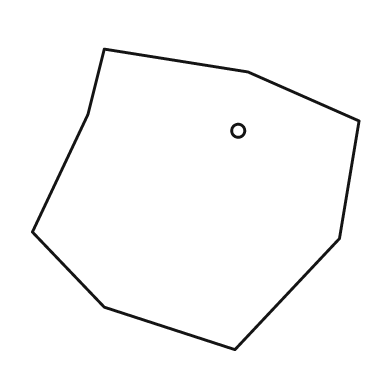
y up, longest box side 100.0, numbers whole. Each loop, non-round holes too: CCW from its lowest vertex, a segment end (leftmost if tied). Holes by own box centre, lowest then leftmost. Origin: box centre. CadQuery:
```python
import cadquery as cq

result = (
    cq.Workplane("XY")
    .moveTo(12.0, -46.0)
    .lineTo(44.0, -12.0)
    .lineTo(50.0, 24.0)
    .lineTo(16.0, 39.0)
    .lineTo(-28.0, 46.0)
    .lineTo(-33.0, 26.0)
    .lineTo(-50.0, -10.0)
    .lineTo(-28.0, -33.0)
    .close()
    .moveTo(13.0, 21.0)
    .circle(2.0)
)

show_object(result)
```